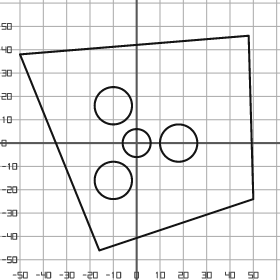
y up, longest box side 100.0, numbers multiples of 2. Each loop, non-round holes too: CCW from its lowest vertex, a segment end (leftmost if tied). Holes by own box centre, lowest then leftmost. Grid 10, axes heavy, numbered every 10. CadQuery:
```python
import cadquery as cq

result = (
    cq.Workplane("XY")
    .moveTo(-16.0, -46.0)
    .lineTo(50.0, -24.0)
    .lineTo(48.0, 46.0)
    .lineTo(-50.0, 38.0)
    .close()
    .moveTo(-10.0, -16.0)
    .circle(8.0)
    .moveTo(0.0, 0.0)
    .circle(6.0)
    .moveTo(18.0, 0.0)
    .circle(8.0)
    .moveTo(-10.0, 16.0)
    .circle(8.0)
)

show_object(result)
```